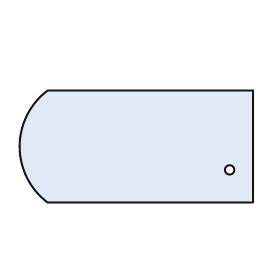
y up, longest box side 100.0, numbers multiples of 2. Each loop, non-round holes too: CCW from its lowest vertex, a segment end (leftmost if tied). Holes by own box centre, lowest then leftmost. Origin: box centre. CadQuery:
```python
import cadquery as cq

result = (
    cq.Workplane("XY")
    .moveTo(-38.0, -24.0)
    .lineTo(50.0, -24.0)
    .lineTo(50.0, 24.0)
    .lineTo(-38.0, 24.0)
    .threePointArc((-50.0, 0.0), (-38.0, -24.0))
    .close()
    .moveTo(40.0, -10.0)
    .circle(2.0)
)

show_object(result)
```